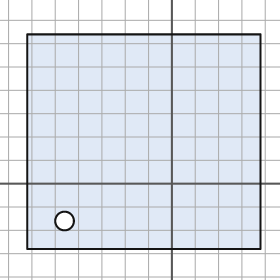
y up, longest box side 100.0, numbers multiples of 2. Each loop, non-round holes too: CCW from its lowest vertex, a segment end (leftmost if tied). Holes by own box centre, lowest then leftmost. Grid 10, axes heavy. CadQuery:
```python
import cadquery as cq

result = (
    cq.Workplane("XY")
    .moveTo(-62.0, -28.0)
    .lineTo(38.0, -28.0)
    .lineTo(38.0, 64.0)
    .lineTo(-62.0, 64.0)
    .close()
    .moveTo(-46.0, -16.0)
    .circle(4.0)
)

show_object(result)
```